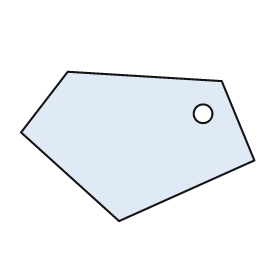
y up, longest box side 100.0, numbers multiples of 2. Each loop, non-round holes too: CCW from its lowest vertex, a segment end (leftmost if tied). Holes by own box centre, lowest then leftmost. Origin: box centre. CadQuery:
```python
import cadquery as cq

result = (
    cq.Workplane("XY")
    .moveTo(-8.0, -32.0)
    .lineTo(50.0, -6.0)
    .lineTo(36.0, 28.0)
    .lineTo(-30.0, 32.0)
    .lineTo(-50.0, 6.0)
    .close()
    .moveTo(28.0, 14.0)
    .circle(4.0)
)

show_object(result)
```